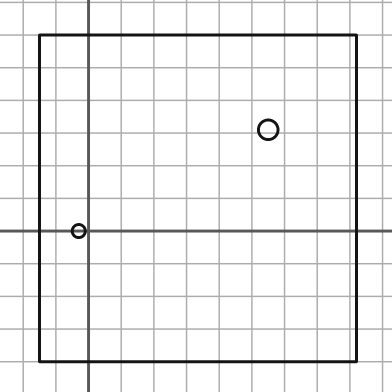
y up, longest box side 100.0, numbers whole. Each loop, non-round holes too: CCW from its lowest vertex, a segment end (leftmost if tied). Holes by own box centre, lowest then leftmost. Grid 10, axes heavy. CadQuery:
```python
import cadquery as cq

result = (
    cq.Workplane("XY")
    .moveTo(-15.0, -40.0)
    .lineTo(82.0, -40.0)
    .lineTo(82.0, 60.0)
    .lineTo(-15.0, 60.0)
    .close()
    .moveTo(-3.0, 0.0)
    .circle(2.0)
    .moveTo(55.0, 31.0)
    .circle(3.0)
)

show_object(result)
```